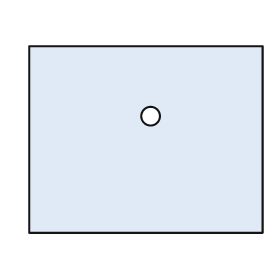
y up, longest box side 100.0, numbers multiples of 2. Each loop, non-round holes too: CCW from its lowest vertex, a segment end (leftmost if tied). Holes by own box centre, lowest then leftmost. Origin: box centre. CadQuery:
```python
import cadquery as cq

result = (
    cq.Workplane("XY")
    .moveTo(-50.0, -40.0)
    .lineTo(50.0, -40.0)
    .lineTo(50.0, 40.0)
    .lineTo(-50.0, 40.0)
    .close()
    .moveTo(2.0, 10.0)
    .circle(4.0)
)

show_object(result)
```